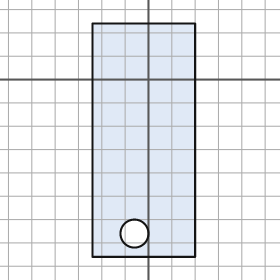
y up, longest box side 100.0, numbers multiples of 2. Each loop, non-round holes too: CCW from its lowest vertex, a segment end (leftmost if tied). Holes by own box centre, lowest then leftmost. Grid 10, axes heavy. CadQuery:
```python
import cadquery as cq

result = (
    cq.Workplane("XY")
    .moveTo(-24.0, -76.0)
    .lineTo(20.0, -76.0)
    .lineTo(20.0, 24.0)
    .lineTo(-24.0, 24.0)
    .close()
    .moveTo(-6.0, -66.0)
    .circle(6.0)
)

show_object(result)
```